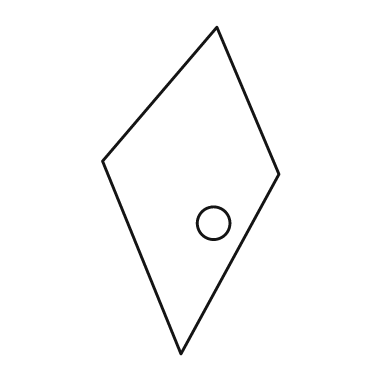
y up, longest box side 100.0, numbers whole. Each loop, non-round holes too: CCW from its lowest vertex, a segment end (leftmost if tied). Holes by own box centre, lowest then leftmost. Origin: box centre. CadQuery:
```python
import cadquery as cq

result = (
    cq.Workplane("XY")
    .moveTo(-3.0, -50.0)
    .lineTo(27.0, 5.0)
    .lineTo(8.0, 50.0)
    .lineTo(-27.0, 9.0)
    .close()
    .moveTo(7.0, -10.0)
    .circle(5.0)
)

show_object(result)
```